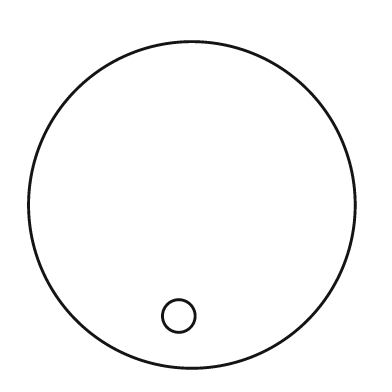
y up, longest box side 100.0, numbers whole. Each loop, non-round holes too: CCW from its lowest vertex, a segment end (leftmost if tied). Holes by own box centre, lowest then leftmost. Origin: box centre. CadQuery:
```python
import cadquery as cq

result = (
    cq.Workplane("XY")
    .moveTo(0.0, 0.0)
    .circle(50.0)
    .moveTo(-4.0, -34.0)
    .circle(5.0)
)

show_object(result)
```